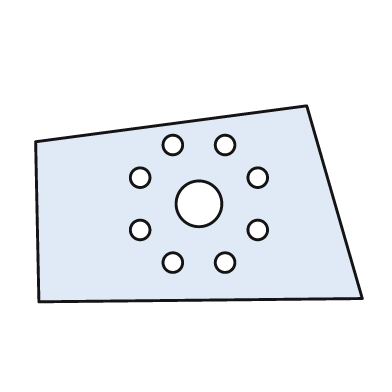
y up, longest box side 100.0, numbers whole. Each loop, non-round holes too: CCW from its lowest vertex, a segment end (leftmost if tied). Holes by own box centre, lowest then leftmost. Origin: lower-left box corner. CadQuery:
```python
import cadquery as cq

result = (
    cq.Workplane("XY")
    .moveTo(1.0, 0.0)
    .lineTo(100.0, 1.0)
    .lineTo(83.0, 60.0)
    .lineTo(0.0, 49.0)
    .close()
    .moveTo(42.0, 12.0)
    .circle(3.0)
    .moveTo(58.0, 12.0)
    .circle(3.0)
    .moveTo(32.0, 22.0)
    .circle(3.0)
    .moveTo(68.0, 22.0)
    .circle(3.0)
    .moveTo(50.0, 30.0)
    .circle(7.0)
    .moveTo(32.0, 38.0)
    .circle(3.0)
    .moveTo(68.0, 38.0)
    .circle(3.0)
    .moveTo(42.0, 48.0)
    .circle(3.0)
    .moveTo(58.0, 48.0)
    .circle(3.0)
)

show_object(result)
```